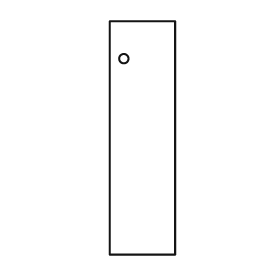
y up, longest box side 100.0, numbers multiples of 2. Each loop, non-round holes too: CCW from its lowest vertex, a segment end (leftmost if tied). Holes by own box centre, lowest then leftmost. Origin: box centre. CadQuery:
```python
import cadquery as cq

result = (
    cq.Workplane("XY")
    .moveTo(-14.0, -50.0)
    .lineTo(14.0, -50.0)
    .lineTo(14.0, 50.0)
    .lineTo(-14.0, 50.0)
    .close()
    .moveTo(-8.0, 34.0)
    .circle(2.0)
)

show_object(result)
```